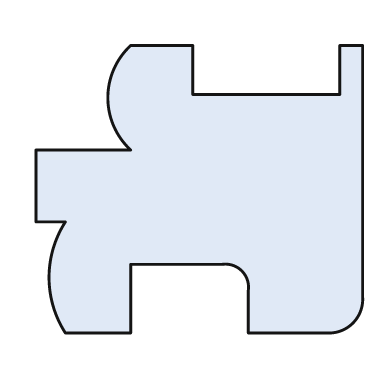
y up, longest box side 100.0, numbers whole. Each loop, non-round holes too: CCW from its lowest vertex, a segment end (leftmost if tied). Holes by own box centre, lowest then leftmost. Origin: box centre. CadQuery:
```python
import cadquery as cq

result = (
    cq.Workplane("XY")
    .moveTo(-41.0, -44.0)
    .lineTo(-21.0, -44.0)
    .lineTo(-21.0, -23.0)
    .lineTo(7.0, -23.0)
    .threePointArc((13.0, -25.0), (15.0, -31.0))
    .lineTo(15.0, -44.0)
    .lineTo(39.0, -44.0)
    .threePointArc((47.0, -41.0), (50.0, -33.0))
    .lineTo(50.0, 44.0)
    .lineTo(43.0, 44.0)
    .lineTo(43.0, 29.0)
    .lineTo(-2.0, 29.0)
    .lineTo(-2.0, 44.0)
    .lineTo(-21.0, 44.0)
    .threePointArc((-28.0, 28.0), (-21.0, 12.0))
    .lineTo(-50.0, 12.0)
    .lineTo(-50.0, -10.0)
    .lineTo(-41.0, -10.0)
    .threePointArc((-46.0, -27.0), (-41.0, -44.0))
    .close()
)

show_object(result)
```